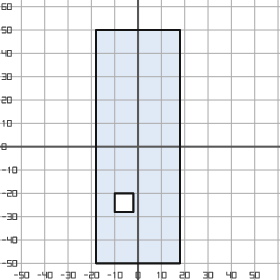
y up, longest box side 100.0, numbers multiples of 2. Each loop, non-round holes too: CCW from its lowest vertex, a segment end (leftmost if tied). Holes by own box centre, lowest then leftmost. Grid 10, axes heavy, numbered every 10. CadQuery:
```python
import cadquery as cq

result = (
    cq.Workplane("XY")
    .moveTo(-18.0, -50.0)
    .lineTo(18.0, -50.0)
    .lineTo(18.0, 50.0)
    .lineTo(-18.0, 50.0)
    .close()
    .moveTo(-10.0, -28.0)
    .lineTo(-2.0, -28.0)
    .lineTo(-2.0, -20.0)
    .lineTo(-10.0, -20.0)
    .close()
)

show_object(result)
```